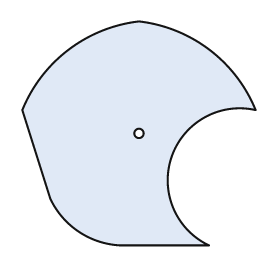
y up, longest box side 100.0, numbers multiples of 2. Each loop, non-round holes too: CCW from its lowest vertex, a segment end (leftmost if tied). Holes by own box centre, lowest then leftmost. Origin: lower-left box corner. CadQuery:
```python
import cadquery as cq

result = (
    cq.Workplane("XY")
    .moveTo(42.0, 0.0)
    .lineTo(80.0, 0.0)
    .threePointArc((64.0, 38.0), (100.0, 58.0))
    .threePointArc((80.0, 84.0), (50.0, 96.0))
    .threePointArc((20.0, 84.0), (0.0, 58.0))
    .lineTo(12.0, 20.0)
    .threePointArc((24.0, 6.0), (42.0, 0.0))
    .close()
    .moveTo(50.0, 48.0)
    .circle(2.0)
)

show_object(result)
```